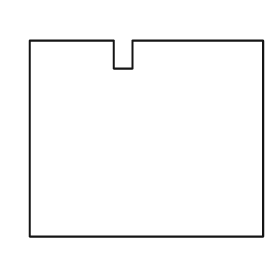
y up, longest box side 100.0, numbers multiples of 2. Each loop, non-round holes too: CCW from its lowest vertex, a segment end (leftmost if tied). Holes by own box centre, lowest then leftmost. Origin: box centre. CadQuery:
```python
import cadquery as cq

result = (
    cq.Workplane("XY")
    .moveTo(-50.0, -42.0)
    .lineTo(50.0, -42.0)
    .lineTo(50.0, 42.0)
    .lineTo(-6.0, 42.0)
    .lineTo(-6.0, 30.0)
    .lineTo(-14.0, 30.0)
    .lineTo(-14.0, 42.0)
    .lineTo(-50.0, 42.0)
    .close()
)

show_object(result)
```